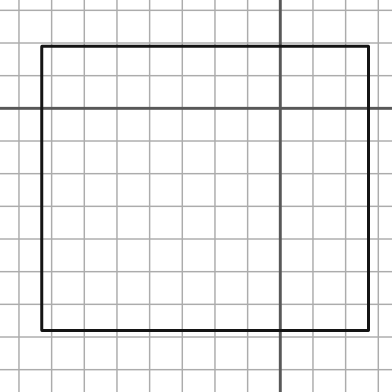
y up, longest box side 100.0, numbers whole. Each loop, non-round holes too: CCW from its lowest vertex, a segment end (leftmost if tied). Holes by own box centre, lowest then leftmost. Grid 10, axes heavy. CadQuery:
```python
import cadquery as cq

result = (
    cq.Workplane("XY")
    .moveTo(-73.0, -68.0)
    .lineTo(27.0, -68.0)
    .lineTo(27.0, 19.0)
    .lineTo(-73.0, 19.0)
    .close()
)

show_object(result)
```